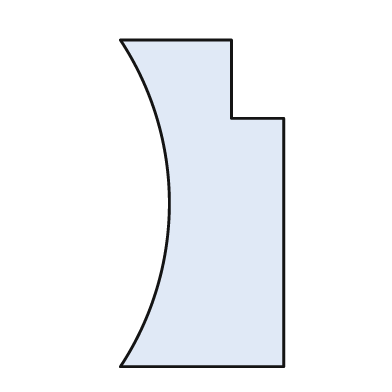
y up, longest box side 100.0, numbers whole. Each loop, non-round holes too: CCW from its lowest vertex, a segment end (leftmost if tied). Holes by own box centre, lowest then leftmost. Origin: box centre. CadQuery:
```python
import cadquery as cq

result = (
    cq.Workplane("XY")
    .moveTo(-25.0, -50.0)
    .lineTo(25.0, -50.0)
    .lineTo(25.0, 26.0)
    .lineTo(9.0, 26.0)
    .lineTo(9.0, 50.0)
    .lineTo(-25.0, 50.0)
    .threePointArc((-10.0, 0.0), (-25.0, -50.0))
    .close()
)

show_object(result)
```